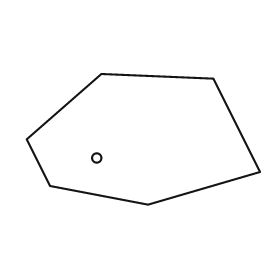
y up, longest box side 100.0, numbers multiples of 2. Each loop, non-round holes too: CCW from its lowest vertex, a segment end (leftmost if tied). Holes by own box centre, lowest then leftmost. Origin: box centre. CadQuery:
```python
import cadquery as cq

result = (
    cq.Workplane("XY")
    .moveTo(2.0, -28.0)
    .lineTo(50.0, -14.0)
    .lineTo(30.0, 26.0)
    .lineTo(-18.0, 28.0)
    .lineTo(-50.0, 0.0)
    .lineTo(-40.0, -20.0)
    .close()
    .moveTo(-20.0, -8.0)
    .circle(2.0)
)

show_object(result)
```